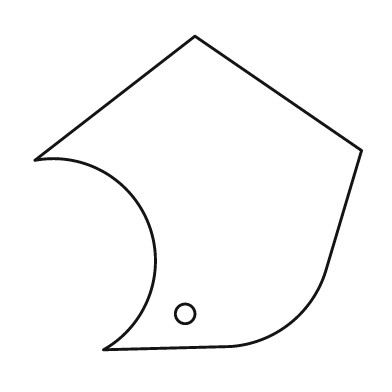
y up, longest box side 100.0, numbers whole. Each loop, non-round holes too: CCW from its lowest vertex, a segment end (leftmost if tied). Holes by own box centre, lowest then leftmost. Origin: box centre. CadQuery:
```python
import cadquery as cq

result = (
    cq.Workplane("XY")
    .moveTo(-29.0, -48.0)
    .lineTo(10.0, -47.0)
    .threePointArc((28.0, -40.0), (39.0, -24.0))
    .lineTo(50.0, 13.0)
    .lineTo(-1.0, 48.0)
    .lineTo(-50.0, 10.0)
    .threePointArc((-15.0, -10.0), (-29.0, -48.0))
    .close()
    .moveTo(-4.0, -37.0)
    .circle(3.0)
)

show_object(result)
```